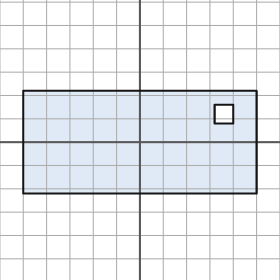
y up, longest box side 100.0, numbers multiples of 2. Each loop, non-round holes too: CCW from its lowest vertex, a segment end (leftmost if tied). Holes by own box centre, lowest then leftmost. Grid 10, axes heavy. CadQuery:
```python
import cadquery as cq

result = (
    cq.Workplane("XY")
    .moveTo(-50.0, -22.0)
    .lineTo(50.0, -22.0)
    .lineTo(50.0, 22.0)
    .lineTo(-50.0, 22.0)
    .close()
    .moveTo(32.0, 8.0)
    .lineTo(40.0, 8.0)
    .lineTo(40.0, 16.0)
    .lineTo(32.0, 16.0)
    .close()
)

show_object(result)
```